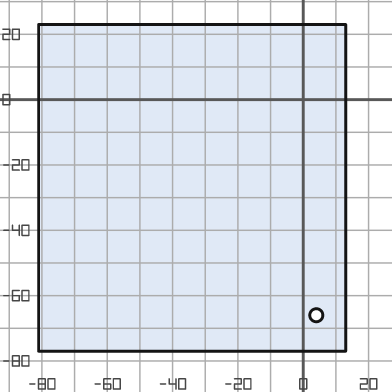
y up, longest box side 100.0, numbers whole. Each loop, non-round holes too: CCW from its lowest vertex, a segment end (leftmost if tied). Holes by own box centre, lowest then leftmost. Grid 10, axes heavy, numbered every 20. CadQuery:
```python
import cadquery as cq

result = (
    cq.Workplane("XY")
    .moveTo(-81.0, -77.0)
    .lineTo(13.0, -77.0)
    .lineTo(13.0, 23.0)
    .lineTo(-81.0, 23.0)
    .close()
    .moveTo(4.0, -66.0)
    .circle(2.0)
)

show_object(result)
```